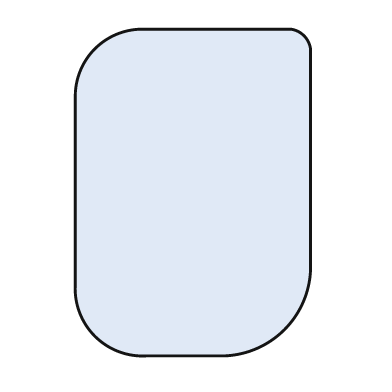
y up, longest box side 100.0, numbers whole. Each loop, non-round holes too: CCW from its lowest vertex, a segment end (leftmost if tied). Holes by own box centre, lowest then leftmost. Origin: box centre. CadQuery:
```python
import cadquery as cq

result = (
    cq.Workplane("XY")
    .moveTo(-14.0, -50.0)
    .lineTo(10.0, -50.0)
    .threePointArc((28.0, -42.0), (36.0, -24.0))
    .lineTo(36.0, 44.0)
    .threePointArc((34.0, 48.0), (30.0, 50.0))
    .lineTo(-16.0, 50.0)
    .threePointArc((-30.0, 44.0), (-36.0, 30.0))
    .lineTo(-36.0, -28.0)
    .threePointArc((-30.0, -44.0), (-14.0, -50.0))
    .close()
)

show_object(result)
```